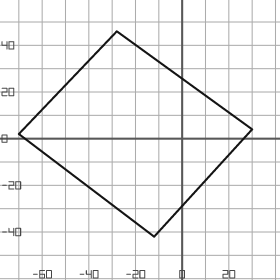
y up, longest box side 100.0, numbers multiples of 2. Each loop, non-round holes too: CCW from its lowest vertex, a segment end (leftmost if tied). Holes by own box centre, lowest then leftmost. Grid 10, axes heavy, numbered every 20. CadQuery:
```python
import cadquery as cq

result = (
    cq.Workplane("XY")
    .moveTo(-12.0, -42.0)
    .lineTo(30.0, 4.0)
    .lineTo(-28.0, 46.0)
    .lineTo(-70.0, 2.0)
    .close()
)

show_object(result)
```